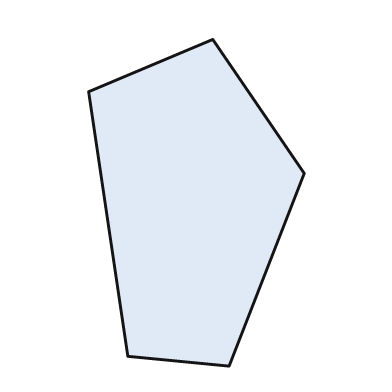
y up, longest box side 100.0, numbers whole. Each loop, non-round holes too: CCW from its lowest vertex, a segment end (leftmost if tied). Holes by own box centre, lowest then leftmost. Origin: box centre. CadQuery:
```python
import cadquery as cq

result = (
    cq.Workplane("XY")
    .moveTo(10.0, -50.0)
    .lineTo(33.0, 9.0)
    .lineTo(5.0, 50.0)
    .lineTo(-33.0, 34.0)
    .lineTo(-21.0, -47.0)
    .close()
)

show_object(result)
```